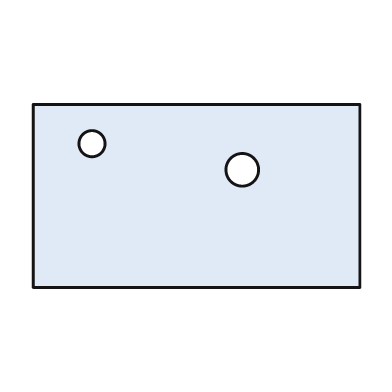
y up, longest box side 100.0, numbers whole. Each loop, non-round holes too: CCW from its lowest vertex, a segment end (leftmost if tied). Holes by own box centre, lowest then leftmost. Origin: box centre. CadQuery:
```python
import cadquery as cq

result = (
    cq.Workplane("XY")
    .moveTo(-50.0, -28.0)
    .lineTo(50.0, -28.0)
    .lineTo(50.0, 28.0)
    .lineTo(-50.0, 28.0)
    .close()
    .moveTo(14.0, 8.0)
    .circle(5.0)
    .moveTo(-32.0, 16.0)
    .circle(4.0)
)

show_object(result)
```